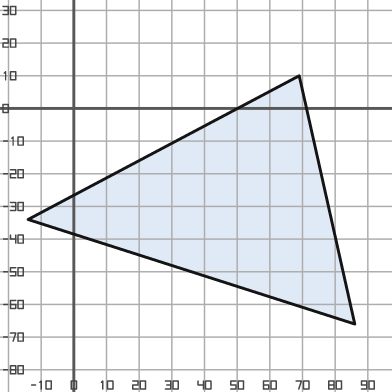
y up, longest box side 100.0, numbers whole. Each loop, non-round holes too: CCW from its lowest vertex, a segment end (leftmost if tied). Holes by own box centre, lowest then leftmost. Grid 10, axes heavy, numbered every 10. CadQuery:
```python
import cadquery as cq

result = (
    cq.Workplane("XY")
    .moveTo(86.0, -66.0)
    .lineTo(69.0, 10.0)
    .lineTo(-14.0, -34.0)
    .close()
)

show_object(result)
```